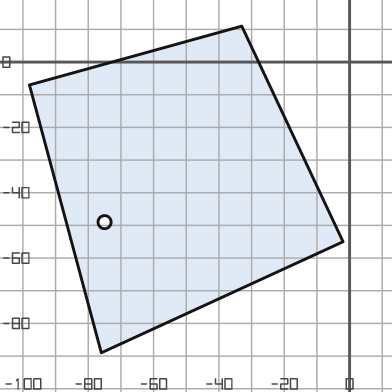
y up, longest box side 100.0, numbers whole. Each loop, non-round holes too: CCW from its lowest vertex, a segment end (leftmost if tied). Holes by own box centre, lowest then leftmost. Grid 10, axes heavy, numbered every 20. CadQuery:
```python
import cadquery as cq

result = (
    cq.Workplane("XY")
    .moveTo(-76.0, -89.0)
    .lineTo(-2.0, -55.0)
    .lineTo(-33.0, 11.0)
    .lineTo(-98.0, -7.0)
    .close()
    .moveTo(-75.0, -49.0)
    .circle(2.0)
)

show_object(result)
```